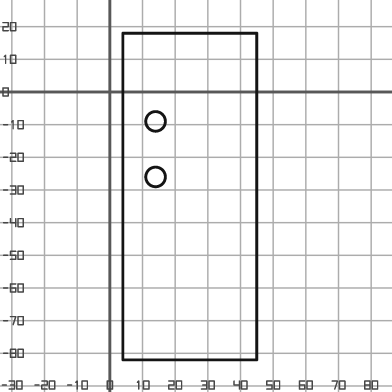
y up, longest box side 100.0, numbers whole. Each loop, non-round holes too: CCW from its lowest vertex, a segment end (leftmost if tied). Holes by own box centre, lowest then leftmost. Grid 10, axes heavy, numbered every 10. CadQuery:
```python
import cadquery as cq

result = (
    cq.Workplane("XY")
    .moveTo(4.0, -82.0)
    .lineTo(45.0, -82.0)
    .lineTo(45.0, 18.0)
    .lineTo(4.0, 18.0)
    .close()
    .moveTo(14.0, -26.0)
    .circle(3.0)
    .moveTo(14.0, -9.0)
    .circle(3.0)
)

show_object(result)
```